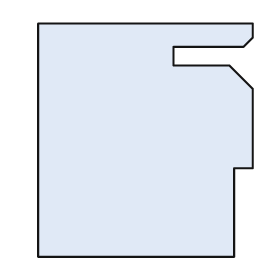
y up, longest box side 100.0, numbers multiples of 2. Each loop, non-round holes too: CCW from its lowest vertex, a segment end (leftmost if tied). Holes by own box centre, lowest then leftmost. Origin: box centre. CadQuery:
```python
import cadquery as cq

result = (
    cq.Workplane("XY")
    .moveTo(-46.0, -50.0)
    .lineTo(38.0, -50.0)
    .lineTo(38.0, -12.0)
    .lineTo(46.0, -12.0)
    .lineTo(46.0, 22.0)
    .lineTo(36.0, 32.0)
    .lineTo(12.0, 32.0)
    .lineTo(12.0, 40.0)
    .lineTo(42.0, 40.0)
    .lineTo(46.0, 44.0)
    .lineTo(46.0, 50.0)
    .lineTo(-46.0, 50.0)
    .close()
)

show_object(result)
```